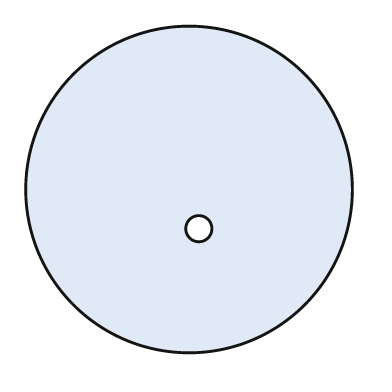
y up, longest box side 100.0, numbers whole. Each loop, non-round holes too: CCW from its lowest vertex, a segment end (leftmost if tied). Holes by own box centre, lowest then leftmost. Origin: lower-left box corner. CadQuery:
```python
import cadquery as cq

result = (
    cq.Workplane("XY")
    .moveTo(50.0, 50.0)
    .circle(50.0)
    .moveTo(53.0, 38.0)
    .circle(4.0)
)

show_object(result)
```